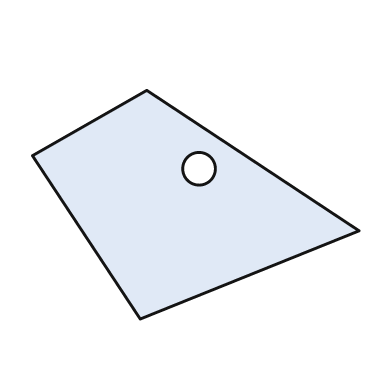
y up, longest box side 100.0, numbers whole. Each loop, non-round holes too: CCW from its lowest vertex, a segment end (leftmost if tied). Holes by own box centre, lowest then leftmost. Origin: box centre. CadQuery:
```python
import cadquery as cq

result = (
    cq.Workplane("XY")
    .moveTo(-17.0, -35.0)
    .lineTo(50.0, -8.0)
    .lineTo(-15.0, 35.0)
    .lineTo(-50.0, 15.0)
    .close()
    .moveTo(1.0, 11.0)
    .circle(5.0)
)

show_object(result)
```